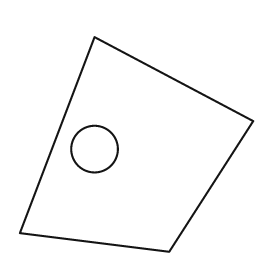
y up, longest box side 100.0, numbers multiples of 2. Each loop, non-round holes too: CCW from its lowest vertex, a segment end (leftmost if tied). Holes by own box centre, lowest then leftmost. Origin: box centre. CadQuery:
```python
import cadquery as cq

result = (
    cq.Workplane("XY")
    .moveTo(14.0, -46.0)
    .lineTo(50.0, 10.0)
    .lineTo(-18.0, 46.0)
    .lineTo(-50.0, -38.0)
    .close()
    .moveTo(-18.0, -2.0)
    .circle(10.0)
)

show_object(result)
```